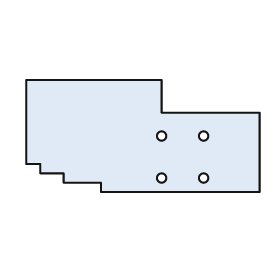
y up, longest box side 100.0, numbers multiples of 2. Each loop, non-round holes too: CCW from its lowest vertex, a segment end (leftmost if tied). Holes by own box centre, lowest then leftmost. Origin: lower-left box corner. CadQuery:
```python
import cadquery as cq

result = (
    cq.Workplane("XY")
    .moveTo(32.0, 0.0)
    .lineTo(100.0, 0.0)
    .lineTo(100.0, 34.0)
    .lineTo(58.0, 34.0)
    .lineTo(58.0, 48.0)
    .lineTo(0.0, 48.0)
    .lineTo(0.0, 12.0)
    .lineTo(6.0, 12.0)
    .lineTo(6.0, 8.0)
    .lineTo(16.0, 8.0)
    .lineTo(16.0, 4.0)
    .lineTo(32.0, 4.0)
    .close()
    .moveTo(58.0, 6.0)
    .circle(2.0)
    .moveTo(76.0, 6.0)
    .circle(2.0)
    .moveTo(58.0, 24.0)
    .circle(2.0)
    .moveTo(76.0, 24.0)
    .circle(2.0)
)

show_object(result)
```